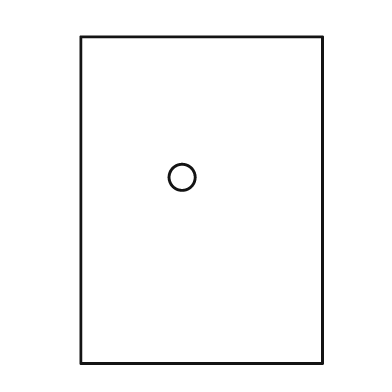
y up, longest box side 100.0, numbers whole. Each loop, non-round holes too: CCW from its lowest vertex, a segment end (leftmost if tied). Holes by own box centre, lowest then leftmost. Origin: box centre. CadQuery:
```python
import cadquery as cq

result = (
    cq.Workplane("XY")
    .moveTo(-37.0, -50.0)
    .lineTo(37.0, -50.0)
    .lineTo(37.0, 50.0)
    .lineTo(-37.0, 50.0)
    .close()
    .moveTo(-6.0, 7.0)
    .circle(4.0)
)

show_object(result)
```